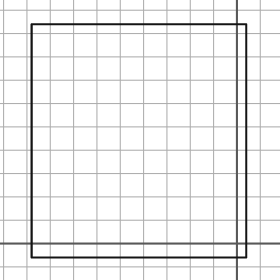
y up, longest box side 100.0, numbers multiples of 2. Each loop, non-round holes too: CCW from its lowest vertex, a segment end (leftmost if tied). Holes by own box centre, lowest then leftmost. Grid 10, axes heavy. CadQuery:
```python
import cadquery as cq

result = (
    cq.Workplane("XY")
    .moveTo(-88.0, -6.0)
    .lineTo(4.0, -6.0)
    .lineTo(4.0, 94.0)
    .lineTo(-88.0, 94.0)
    .close()
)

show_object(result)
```